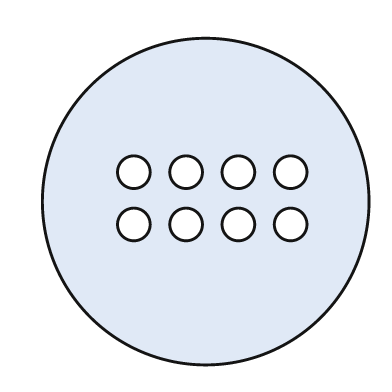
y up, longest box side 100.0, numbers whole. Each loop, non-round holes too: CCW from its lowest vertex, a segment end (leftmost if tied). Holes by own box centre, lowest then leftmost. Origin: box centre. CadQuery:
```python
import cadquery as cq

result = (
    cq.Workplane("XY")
    .moveTo(0.0, 0.0)
    .circle(50.0)
    .moveTo(-22.0, -7.0)
    .circle(5.0)
    .moveTo(-6.0, -7.0)
    .circle(5.0)
    .moveTo(10.0, -7.0)
    .circle(5.0)
    .moveTo(26.0, -7.0)
    .circle(5.0)
    .moveTo(-22.0, 9.0)
    .circle(5.0)
    .moveTo(-6.0, 9.0)
    .circle(5.0)
    .moveTo(10.0, 9.0)
    .circle(5.0)
    .moveTo(26.0, 9.0)
    .circle(5.0)
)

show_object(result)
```